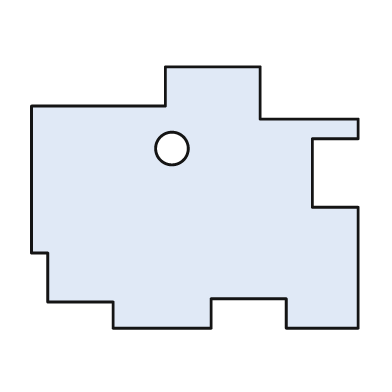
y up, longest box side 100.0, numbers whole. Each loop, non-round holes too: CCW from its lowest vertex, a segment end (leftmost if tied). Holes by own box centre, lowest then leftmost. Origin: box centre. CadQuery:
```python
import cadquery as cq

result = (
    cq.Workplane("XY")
    .moveTo(-25.0, -40.0)
    .lineTo(5.0, -40.0)
    .lineTo(5.0, -31.0)
    .lineTo(28.0, -31.0)
    .lineTo(28.0, -40.0)
    .lineTo(50.0, -40.0)
    .lineTo(50.0, -3.0)
    .lineTo(36.0, -3.0)
    .lineTo(36.0, 18.0)
    .lineTo(50.0, 18.0)
    .lineTo(50.0, 24.0)
    .lineTo(20.0, 24.0)
    .lineTo(20.0, 40.0)
    .lineTo(-9.0, 40.0)
    .lineTo(-9.0, 28.0)
    .lineTo(-50.0, 28.0)
    .lineTo(-50.0, -17.0)
    .lineTo(-45.0, -17.0)
    .lineTo(-45.0, -32.0)
    .lineTo(-25.0, -32.0)
    .close()
    .moveTo(-7.0, 15.0)
    .circle(5.0)
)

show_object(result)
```